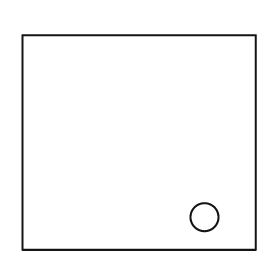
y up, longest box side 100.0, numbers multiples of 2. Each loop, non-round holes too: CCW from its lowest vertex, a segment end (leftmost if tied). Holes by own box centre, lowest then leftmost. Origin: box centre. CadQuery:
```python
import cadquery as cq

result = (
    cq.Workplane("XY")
    .moveTo(-50.0, -46.0)
    .lineTo(50.0, -46.0)
    .lineTo(50.0, 46.0)
    .lineTo(-50.0, 46.0)
    .close()
    .moveTo(28.0, -32.0)
    .circle(6.0)
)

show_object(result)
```